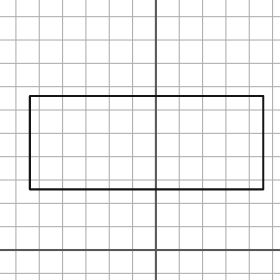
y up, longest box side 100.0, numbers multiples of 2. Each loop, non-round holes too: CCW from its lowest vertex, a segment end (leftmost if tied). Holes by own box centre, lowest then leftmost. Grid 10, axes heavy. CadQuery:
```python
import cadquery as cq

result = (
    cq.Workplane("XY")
    .moveTo(-54.0, 26.0)
    .lineTo(46.0, 26.0)
    .lineTo(46.0, 66.0)
    .lineTo(-54.0, 66.0)
    .close()
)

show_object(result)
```